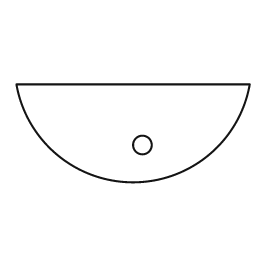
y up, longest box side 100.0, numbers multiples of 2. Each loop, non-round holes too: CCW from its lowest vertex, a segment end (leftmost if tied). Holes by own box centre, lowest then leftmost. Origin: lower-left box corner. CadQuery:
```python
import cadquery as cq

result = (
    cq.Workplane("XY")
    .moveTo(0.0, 42.0)
    .threePointArc((50.0, 0.0), (100.0, 42.0))
    .close()
    .moveTo(54.0, 16.0)
    .circle(4.0)
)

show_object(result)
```